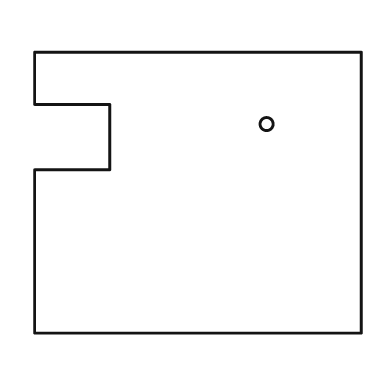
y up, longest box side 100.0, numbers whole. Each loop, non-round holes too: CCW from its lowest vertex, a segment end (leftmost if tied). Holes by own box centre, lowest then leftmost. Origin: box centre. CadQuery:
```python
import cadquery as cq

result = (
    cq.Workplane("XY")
    .moveTo(-50.0, -43.0)
    .lineTo(50.0, -43.0)
    .lineTo(50.0, 43.0)
    .lineTo(-50.0, 43.0)
    .lineTo(-50.0, 27.0)
    .lineTo(-27.0, 27.0)
    .lineTo(-27.0, 7.0)
    .lineTo(-50.0, 7.0)
    .close()
    .moveTo(21.0, 21.0)
    .circle(2.0)
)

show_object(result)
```